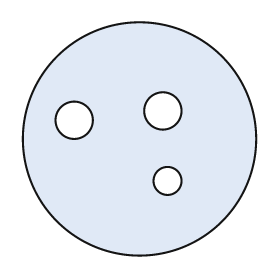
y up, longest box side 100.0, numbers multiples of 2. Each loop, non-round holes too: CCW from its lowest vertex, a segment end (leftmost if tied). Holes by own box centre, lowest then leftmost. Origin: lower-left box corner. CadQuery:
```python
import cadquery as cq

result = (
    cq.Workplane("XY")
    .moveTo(50.0, 50.0)
    .circle(50.0)
    .moveTo(62.0, 32.0)
    .circle(6.0)
    .moveTo(22.0, 58.0)
    .circle(8.0)
    .moveTo(60.0, 62.0)
    .circle(8.0)
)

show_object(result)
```